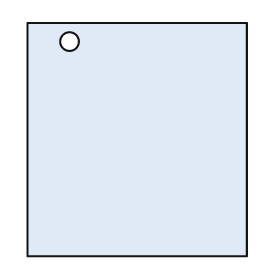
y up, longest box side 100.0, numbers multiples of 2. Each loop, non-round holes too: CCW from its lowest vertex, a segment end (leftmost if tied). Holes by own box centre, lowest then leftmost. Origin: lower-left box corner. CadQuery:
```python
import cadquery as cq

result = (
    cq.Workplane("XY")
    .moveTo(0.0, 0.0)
    .lineTo(94.0, 0.0)
    .lineTo(94.0, 100.0)
    .lineTo(0.0, 100.0)
    .close()
    .moveTo(18.0, 92.0)
    .circle(4.0)
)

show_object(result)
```